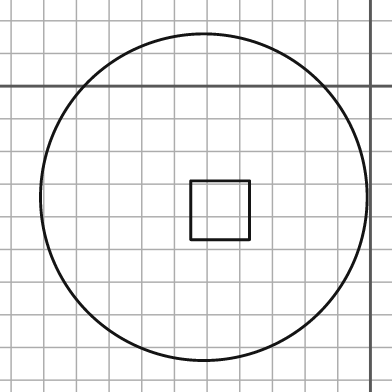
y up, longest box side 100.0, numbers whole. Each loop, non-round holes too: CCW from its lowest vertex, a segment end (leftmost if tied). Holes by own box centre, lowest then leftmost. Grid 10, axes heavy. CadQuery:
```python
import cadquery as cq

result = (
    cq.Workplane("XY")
    .moveTo(-51.0, -34.0)
    .circle(50.0)
    .moveTo(-55.0, -47.0)
    .lineTo(-37.0, -47.0)
    .lineTo(-37.0, -29.0)
    .lineTo(-55.0, -29.0)
    .close()
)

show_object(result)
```